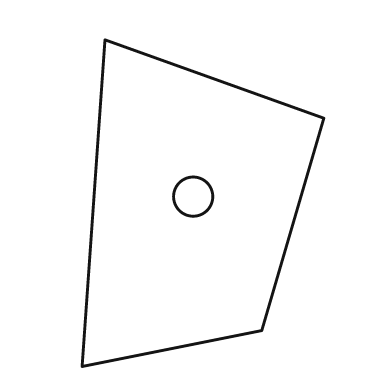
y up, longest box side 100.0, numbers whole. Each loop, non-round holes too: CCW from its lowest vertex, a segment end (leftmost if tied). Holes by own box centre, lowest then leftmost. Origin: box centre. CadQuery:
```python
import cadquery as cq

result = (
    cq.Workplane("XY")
    .moveTo(-37.0, -50.0)
    .lineTo(18.0, -39.0)
    .lineTo(37.0, 26.0)
    .lineTo(-30.0, 50.0)
    .close()
    .moveTo(-3.0, 2.0)
    .circle(6.0)
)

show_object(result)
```